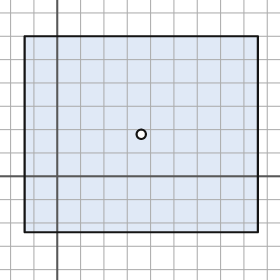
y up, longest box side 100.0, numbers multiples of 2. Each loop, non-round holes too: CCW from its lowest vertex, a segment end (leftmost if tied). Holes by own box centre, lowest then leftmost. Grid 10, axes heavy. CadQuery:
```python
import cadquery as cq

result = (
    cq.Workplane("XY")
    .moveTo(-14.0, -24.0)
    .lineTo(86.0, -24.0)
    .lineTo(86.0, 60.0)
    .lineTo(-14.0, 60.0)
    .close()
    .moveTo(36.0, 18.0)
    .circle(2.0)
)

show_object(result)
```